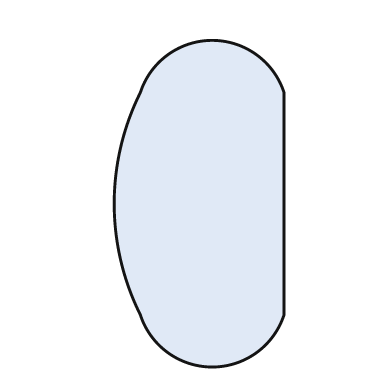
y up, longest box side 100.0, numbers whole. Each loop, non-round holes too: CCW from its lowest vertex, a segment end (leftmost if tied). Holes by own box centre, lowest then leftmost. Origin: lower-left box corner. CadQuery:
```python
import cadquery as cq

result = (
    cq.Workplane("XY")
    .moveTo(8.0, 16.0)
    .threePointArc((30.0, 0.0), (52.0, 16.0))
    .lineTo(52.0, 84.0)
    .threePointArc((30.0, 100.0), (8.0, 84.0))
    .threePointArc((0.0, 50.0), (8.0, 16.0))
    .close()
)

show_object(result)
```